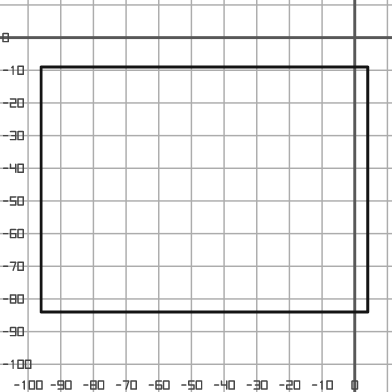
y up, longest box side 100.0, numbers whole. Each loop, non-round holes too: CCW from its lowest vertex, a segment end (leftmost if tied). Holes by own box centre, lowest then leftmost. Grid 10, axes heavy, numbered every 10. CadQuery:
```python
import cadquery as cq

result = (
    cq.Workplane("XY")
    .moveTo(-96.0, -84.0)
    .lineTo(4.0, -84.0)
    .lineTo(4.0, -9.0)
    .lineTo(-96.0, -9.0)
    .close()
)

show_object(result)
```